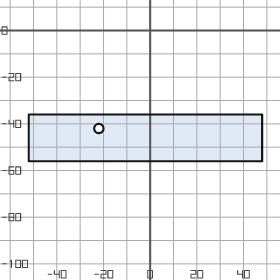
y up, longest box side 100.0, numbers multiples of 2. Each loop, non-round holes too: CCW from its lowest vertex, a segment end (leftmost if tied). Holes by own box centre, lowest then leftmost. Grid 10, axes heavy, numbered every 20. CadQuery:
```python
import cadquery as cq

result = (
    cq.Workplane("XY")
    .moveTo(-52.0, -56.0)
    .lineTo(48.0, -56.0)
    .lineTo(48.0, -36.0)
    .lineTo(-52.0, -36.0)
    .close()
    .moveTo(-22.0, -42.0)
    .circle(2.0)
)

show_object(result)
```